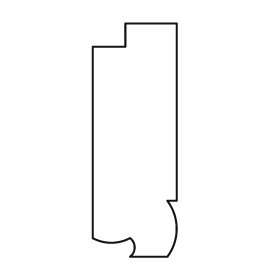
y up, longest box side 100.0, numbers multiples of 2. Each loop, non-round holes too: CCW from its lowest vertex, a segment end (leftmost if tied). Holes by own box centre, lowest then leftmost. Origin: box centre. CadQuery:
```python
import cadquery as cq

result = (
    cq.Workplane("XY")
    .moveTo(-2.0, -50.0)
    .lineTo(14.0, -50.0)
    .threePointArc((18.0, -38.0), (14.0, -26.0))
    .lineTo(18.0, -26.0)
    .lineTo(18.0, 50.0)
    .lineTo(-4.0, 50.0)
    .lineTo(-4.0, 40.0)
    .lineTo(-18.0, 40.0)
    .lineTo(-18.0, -42.0)
    .threePointArc((-10.0, -44.0), (-2.0, -42.0))
    .threePointArc((0.0, -46.0), (-2.0, -50.0))
    .close()
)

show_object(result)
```